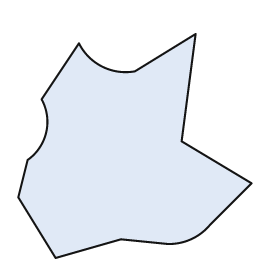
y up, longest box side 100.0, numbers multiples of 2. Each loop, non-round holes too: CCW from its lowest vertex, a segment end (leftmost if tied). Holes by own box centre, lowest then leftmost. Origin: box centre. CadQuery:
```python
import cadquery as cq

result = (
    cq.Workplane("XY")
    .moveTo(-34.0, -48.0)
    .lineTo(-6.0, -40.0)
    .lineTo(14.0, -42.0)
    .threePointArc((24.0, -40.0), (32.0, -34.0))
    .lineTo(50.0, -16.0)
    .lineTo(20.0, 2.0)
    .lineTo(26.0, 48.0)
    .lineTo(0.0, 32.0)
    .threePointArc((-14.0, 34.0), (-24.0, 44.0))
    .lineTo(-40.0, 20.0)
    .threePointArc((-38.0, 6.0), (-46.0, -6.0))
    .lineTo(-50.0, -22.0)
    .close()
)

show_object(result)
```